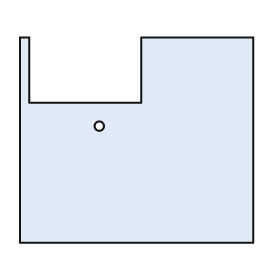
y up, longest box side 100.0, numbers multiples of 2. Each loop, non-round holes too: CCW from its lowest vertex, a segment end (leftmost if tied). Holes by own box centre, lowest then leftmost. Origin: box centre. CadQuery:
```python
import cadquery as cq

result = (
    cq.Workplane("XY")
    .moveTo(-50.0, -44.0)
    .lineTo(50.0, -44.0)
    .lineTo(50.0, 44.0)
    .lineTo(2.0, 44.0)
    .lineTo(2.0, 16.0)
    .lineTo(-46.0, 16.0)
    .lineTo(-46.0, 44.0)
    .lineTo(-50.0, 44.0)
    .close()
    .moveTo(-16.0, 6.0)
    .circle(2.0)
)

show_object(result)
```